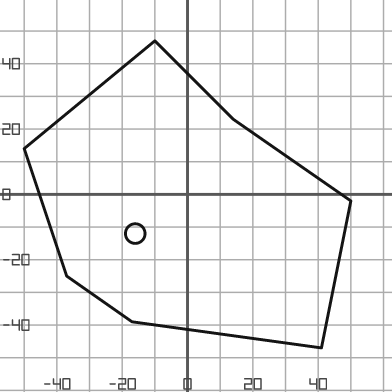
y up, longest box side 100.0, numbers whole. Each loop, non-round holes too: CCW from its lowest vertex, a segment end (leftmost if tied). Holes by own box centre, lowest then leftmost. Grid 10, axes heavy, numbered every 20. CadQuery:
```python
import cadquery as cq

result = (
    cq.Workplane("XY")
    .moveTo(41.0, -47.0)
    .lineTo(50.0, -2.0)
    .lineTo(14.0, 23.0)
    .lineTo(-10.0, 47.0)
    .lineTo(-50.0, 14.0)
    .lineTo(-37.0, -25.0)
    .lineTo(-17.0, -39.0)
    .close()
    .moveTo(-16.0, -12.0)
    .circle(3.0)
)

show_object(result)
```